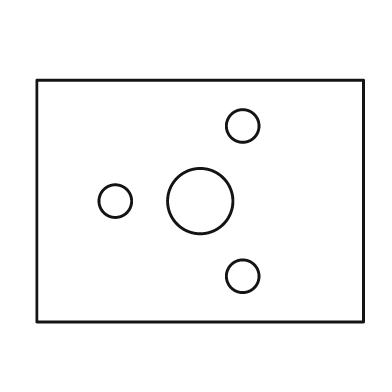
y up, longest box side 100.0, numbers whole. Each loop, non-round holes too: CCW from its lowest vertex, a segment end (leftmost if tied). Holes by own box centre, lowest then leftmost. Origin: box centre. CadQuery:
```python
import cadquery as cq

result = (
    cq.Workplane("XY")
    .moveTo(-50.0, -37.0)
    .lineTo(50.0, -37.0)
    .lineTo(50.0, 37.0)
    .lineTo(-50.0, 37.0)
    .close()
    .moveTo(13.0, -23.0)
    .circle(5.0)
    .moveTo(-26.0, 0.0)
    .circle(5.0)
    .moveTo(0.0, 0.0)
    .circle(10.0)
    .moveTo(13.0, 23.0)
    .circle(5.0)
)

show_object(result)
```